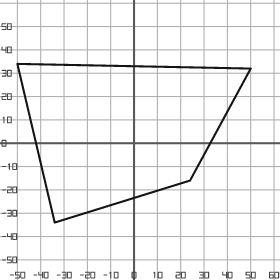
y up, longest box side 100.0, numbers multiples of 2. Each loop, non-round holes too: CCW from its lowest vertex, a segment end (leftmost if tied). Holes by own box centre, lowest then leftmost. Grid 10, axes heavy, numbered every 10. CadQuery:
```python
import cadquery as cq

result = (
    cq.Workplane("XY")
    .moveTo(-34.0, -34.0)
    .lineTo(24.0, -16.0)
    .lineTo(50.0, 32.0)
    .lineTo(-50.0, 34.0)
    .close()
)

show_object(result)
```